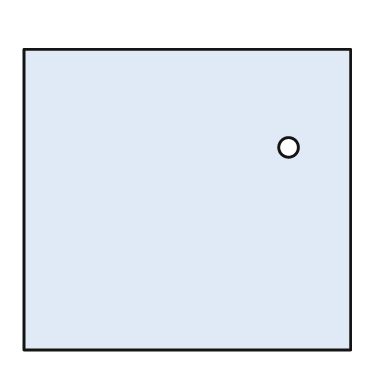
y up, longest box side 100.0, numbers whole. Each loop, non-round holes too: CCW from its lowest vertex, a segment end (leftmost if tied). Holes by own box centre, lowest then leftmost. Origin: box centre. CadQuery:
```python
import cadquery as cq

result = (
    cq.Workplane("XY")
    .moveTo(-50.0, -46.0)
    .lineTo(50.0, -46.0)
    .lineTo(50.0, 46.0)
    .lineTo(-50.0, 46.0)
    .close()
    .moveTo(31.0, 16.0)
    .circle(3.0)
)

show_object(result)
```